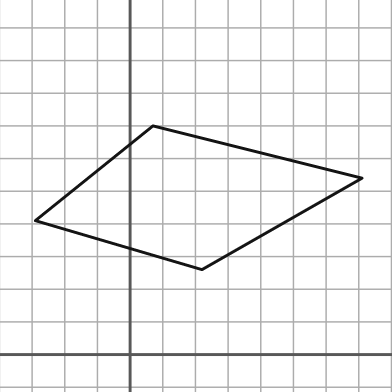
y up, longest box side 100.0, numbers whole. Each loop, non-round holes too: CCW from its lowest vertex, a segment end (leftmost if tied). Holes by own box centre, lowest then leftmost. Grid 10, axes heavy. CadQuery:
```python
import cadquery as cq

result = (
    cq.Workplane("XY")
    .moveTo(22.0, 26.0)
    .lineTo(71.0, 54.0)
    .lineTo(7.0, 70.0)
    .lineTo(-29.0, 41.0)
    .close()
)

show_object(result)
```